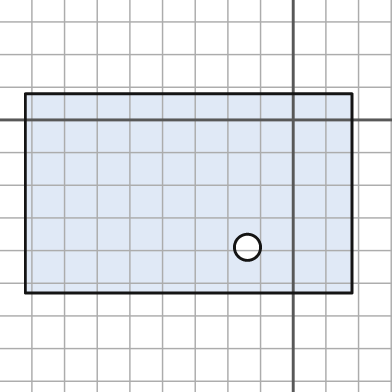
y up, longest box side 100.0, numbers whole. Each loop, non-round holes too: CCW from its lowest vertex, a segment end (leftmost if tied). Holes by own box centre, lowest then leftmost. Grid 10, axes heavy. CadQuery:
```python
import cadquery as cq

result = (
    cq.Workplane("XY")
    .moveTo(-82.0, -53.0)
    .lineTo(18.0, -53.0)
    .lineTo(18.0, 8.0)
    .lineTo(-82.0, 8.0)
    .close()
    .moveTo(-14.0, -39.0)
    .circle(4.0)
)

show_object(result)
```